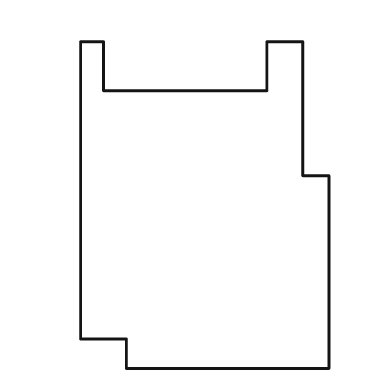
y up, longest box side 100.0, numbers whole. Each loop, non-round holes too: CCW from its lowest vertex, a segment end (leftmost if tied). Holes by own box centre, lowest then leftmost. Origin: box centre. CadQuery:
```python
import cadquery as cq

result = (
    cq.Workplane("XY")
    .moveTo(-24.0, -50.0)
    .lineTo(38.0, -50.0)
    .lineTo(38.0, 9.0)
    .lineTo(30.0, 9.0)
    .lineTo(30.0, 50.0)
    .lineTo(19.0, 50.0)
    .lineTo(19.0, 35.0)
    .lineTo(-31.0, 35.0)
    .lineTo(-31.0, 50.0)
    .lineTo(-38.0, 50.0)
    .lineTo(-38.0, -41.0)
    .lineTo(-24.0, -41.0)
    .close()
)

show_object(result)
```